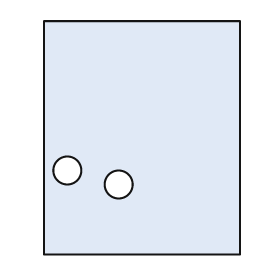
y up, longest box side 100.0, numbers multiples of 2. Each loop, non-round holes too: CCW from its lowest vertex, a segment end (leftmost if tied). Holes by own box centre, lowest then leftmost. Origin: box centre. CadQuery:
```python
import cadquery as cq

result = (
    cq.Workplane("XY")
    .moveTo(-42.0, -50.0)
    .lineTo(42.0, -50.0)
    .lineTo(42.0, 50.0)
    .lineTo(-42.0, 50.0)
    .close()
    .moveTo(-10.0, -20.0)
    .circle(6.0)
    .moveTo(-32.0, -14.0)
    .circle(6.0)
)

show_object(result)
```